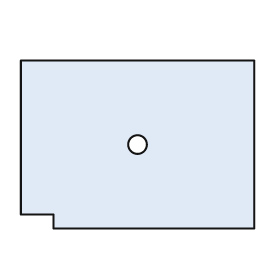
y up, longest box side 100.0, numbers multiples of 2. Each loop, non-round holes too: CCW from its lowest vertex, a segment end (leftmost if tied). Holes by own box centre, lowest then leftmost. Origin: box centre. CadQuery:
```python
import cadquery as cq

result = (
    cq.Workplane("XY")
    .moveTo(-36.0, -36.0)
    .lineTo(50.0, -36.0)
    .lineTo(50.0, 36.0)
    .lineTo(-50.0, 36.0)
    .lineTo(-50.0, -30.0)
    .lineTo(-36.0, -30.0)
    .close()
    .moveTo(0.0, 0.0)
    .circle(4.0)
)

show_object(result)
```